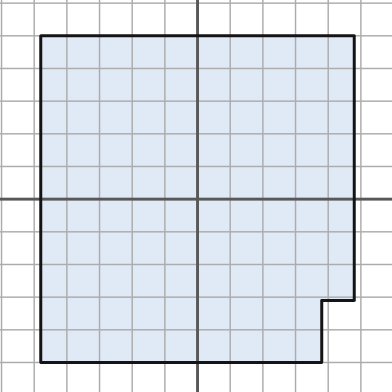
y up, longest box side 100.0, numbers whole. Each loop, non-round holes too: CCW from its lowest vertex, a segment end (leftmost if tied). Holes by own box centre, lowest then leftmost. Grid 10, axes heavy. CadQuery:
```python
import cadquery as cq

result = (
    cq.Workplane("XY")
    .moveTo(-48.0, -50.0)
    .lineTo(38.0, -50.0)
    .lineTo(38.0, -31.0)
    .lineTo(48.0, -31.0)
    .lineTo(48.0, 50.0)
    .lineTo(-48.0, 50.0)
    .close()
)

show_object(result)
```